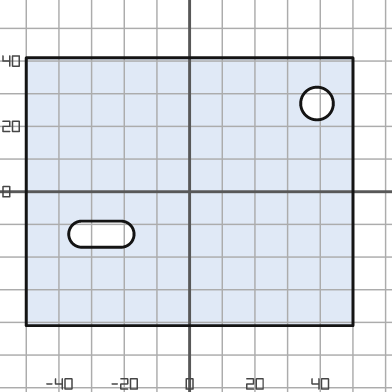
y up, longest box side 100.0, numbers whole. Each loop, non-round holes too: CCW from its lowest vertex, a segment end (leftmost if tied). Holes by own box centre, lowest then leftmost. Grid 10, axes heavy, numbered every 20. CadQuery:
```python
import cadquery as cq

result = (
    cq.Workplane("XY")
    .moveTo(-50.0, -41.0)
    .lineTo(50.0, -41.0)
    .lineTo(50.0, 41.0)
    .lineTo(-50.0, 41.0)
    .close()
    .moveTo(-33.0, -17.0)
    .lineTo(-21.0, -17.0)
    .threePointArc((-17.0, -13.0), (-21.0, -9.0))
    .lineTo(-33.0, -9.0)
    .threePointArc((-37.0, -13.0), (-33.0, -17.0))
    .close()
    .moveTo(39.0, 27.0)
    .circle(5.0)
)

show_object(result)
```